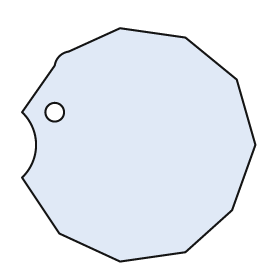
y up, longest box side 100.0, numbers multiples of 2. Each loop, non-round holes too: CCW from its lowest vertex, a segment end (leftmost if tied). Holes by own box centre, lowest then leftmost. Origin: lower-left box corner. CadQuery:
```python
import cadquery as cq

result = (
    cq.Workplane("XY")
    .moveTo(42.0, 0.0)
    .lineTo(70.0, 4.0)
    .lineTo(90.0, 22.0)
    .lineTo(100.0, 50.0)
    .lineTo(92.0, 78.0)
    .lineTo(70.0, 96.0)
    .lineTo(42.0, 100.0)
    .lineTo(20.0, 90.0)
    .threePointArc((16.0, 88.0), (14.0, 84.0))
    .lineTo(0.0, 64.0)
    .threePointArc((6.0, 50.0), (0.0, 36.0))
    .lineTo(16.0, 12.0)
    .close()
    .moveTo(14.0, 64.0)
    .circle(4.0)
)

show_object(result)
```